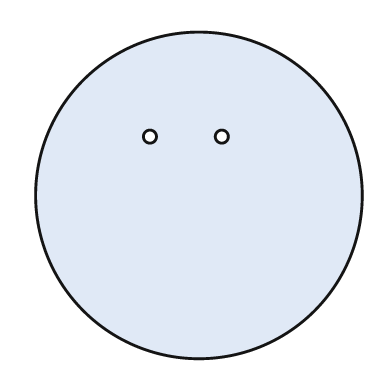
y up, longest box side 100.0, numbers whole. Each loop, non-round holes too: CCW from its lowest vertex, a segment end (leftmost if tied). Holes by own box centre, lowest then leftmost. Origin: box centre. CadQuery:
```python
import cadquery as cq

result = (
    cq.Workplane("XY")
    .moveTo(0.0, 0.0)
    .circle(50.0)
    .moveTo(-15.0, 18.0)
    .circle(2.0)
    .moveTo(7.0, 18.0)
    .circle(2.0)
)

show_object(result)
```